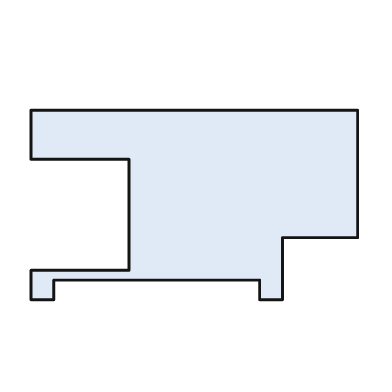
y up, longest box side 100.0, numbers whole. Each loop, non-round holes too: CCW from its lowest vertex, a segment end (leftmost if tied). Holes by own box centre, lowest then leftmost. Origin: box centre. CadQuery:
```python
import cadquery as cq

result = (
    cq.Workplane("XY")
    .moveTo(-50.0, -29.0)
    .lineTo(-43.0, -29.0)
    .lineTo(-43.0, -23.0)
    .lineTo(20.0, -23.0)
    .lineTo(20.0, -29.0)
    .lineTo(27.0, -29.0)
    .lineTo(27.0, -10.0)
    .lineTo(50.0, -10.0)
    .lineTo(50.0, 29.0)
    .lineTo(-50.0, 29.0)
    .lineTo(-50.0, 14.0)
    .lineTo(-20.0, 14.0)
    .lineTo(-20.0, -20.0)
    .lineTo(-50.0, -20.0)
    .close()
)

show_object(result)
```